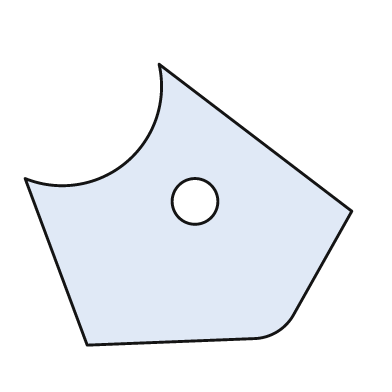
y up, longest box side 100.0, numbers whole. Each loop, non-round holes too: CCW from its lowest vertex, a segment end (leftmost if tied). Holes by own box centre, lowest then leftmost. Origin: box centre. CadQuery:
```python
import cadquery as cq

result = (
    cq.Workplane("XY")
    .moveTo(-31.0, -43.0)
    .lineTo(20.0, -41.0)
    .threePointArc((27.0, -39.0), (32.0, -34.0))
    .lineTo(50.0, -2.0)
    .lineTo(-9.0, 43.0)
    .threePointArc((-19.0, 13.0), (-50.0, 8.0))
    .close()
    .moveTo(2.0, 1.0)
    .circle(7.0)
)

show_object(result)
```